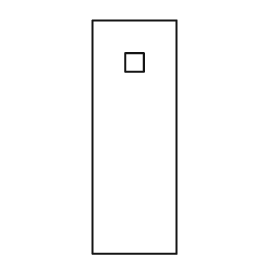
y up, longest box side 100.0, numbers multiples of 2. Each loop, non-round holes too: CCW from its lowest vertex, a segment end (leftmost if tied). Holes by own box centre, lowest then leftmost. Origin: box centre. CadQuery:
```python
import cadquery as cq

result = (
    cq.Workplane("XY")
    .moveTo(-18.0, -50.0)
    .lineTo(18.0, -50.0)
    .lineTo(18.0, 50.0)
    .lineTo(-18.0, 50.0)
    .close()
    .moveTo(-4.0, 28.0)
    .lineTo(4.0, 28.0)
    .lineTo(4.0, 36.0)
    .lineTo(-4.0, 36.0)
    .close()
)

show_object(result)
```